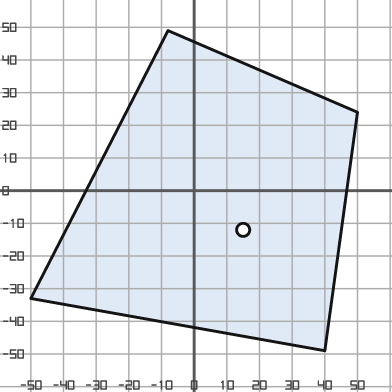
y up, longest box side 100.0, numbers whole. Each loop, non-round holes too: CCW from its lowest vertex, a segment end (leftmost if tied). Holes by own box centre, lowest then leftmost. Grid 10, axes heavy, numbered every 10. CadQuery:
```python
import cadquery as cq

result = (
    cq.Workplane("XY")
    .moveTo(40.0, -49.0)
    .lineTo(50.0, 24.0)
    .lineTo(-8.0, 49.0)
    .lineTo(-50.0, -33.0)
    .close()
    .moveTo(15.0, -12.0)
    .circle(2.0)
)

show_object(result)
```